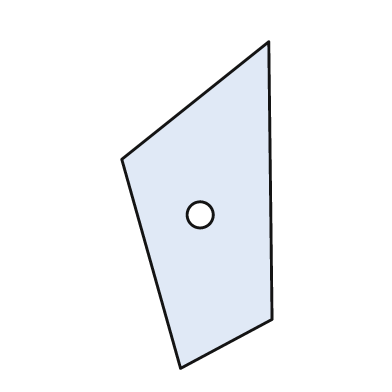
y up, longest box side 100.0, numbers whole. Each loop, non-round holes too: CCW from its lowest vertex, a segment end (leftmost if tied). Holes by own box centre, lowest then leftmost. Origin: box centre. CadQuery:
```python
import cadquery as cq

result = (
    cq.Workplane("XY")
    .moveTo(-5.0, -50.0)
    .lineTo(23.0, -35.0)
    .lineTo(22.0, 50.0)
    .lineTo(-23.0, 14.0)
    .close()
    .moveTo(1.0, -3.0)
    .circle(4.0)
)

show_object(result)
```